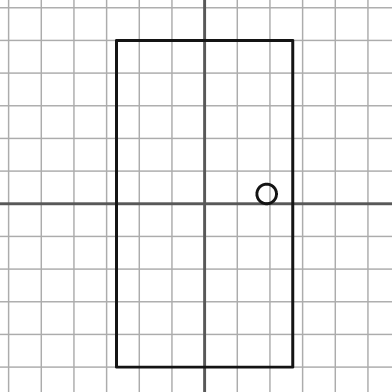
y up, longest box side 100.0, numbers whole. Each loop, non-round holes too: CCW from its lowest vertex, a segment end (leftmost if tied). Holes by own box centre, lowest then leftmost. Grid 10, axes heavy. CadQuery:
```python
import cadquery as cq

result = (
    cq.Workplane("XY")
    .moveTo(-27.0, -50.0)
    .lineTo(27.0, -50.0)
    .lineTo(27.0, 50.0)
    .lineTo(-27.0, 50.0)
    .close()
    .moveTo(19.0, 3.0)
    .circle(3.0)
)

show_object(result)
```